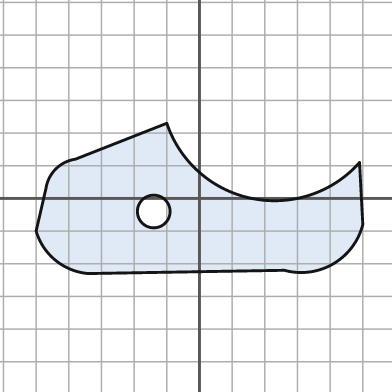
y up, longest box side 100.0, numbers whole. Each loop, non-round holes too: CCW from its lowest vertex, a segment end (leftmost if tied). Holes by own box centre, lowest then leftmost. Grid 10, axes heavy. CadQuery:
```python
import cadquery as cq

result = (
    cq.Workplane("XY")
    .moveTo(-34.0, -23.0)
    .lineTo(26.0, -22.0)
    .threePointArc((41.0, -20.0), (50.0, -8.0))
    .lineTo(49.0, 11.0)
    .threePointArc((16.0, 0.0), (-10.0, 23.0))
    .lineTo(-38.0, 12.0)
    .threePointArc((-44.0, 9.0), (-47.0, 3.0))
    .lineTo(-50.0, -10.0)
    .threePointArc((-44.0, -19.0), (-34.0, -23.0))
    .close()
    .moveTo(-14.0, -4.0)
    .circle(5.0)
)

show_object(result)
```